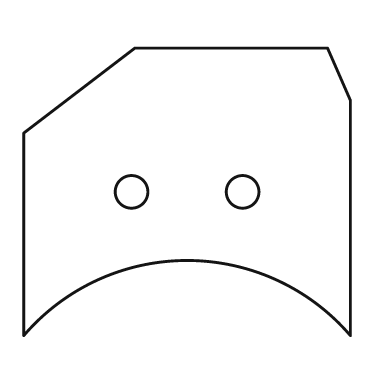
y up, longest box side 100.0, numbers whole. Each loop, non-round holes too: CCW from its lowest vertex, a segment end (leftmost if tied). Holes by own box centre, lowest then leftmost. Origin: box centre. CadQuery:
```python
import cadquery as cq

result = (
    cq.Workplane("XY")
    .moveTo(-50.0, -44.0)
    .threePointArc((0.0, -21.0), (50.0, -44.0))
    .lineTo(50.0, 28.0)
    .lineTo(43.0, 44.0)
    .lineTo(-16.0, 44.0)
    .lineTo(-50.0, 18.0)
    .close()
    .moveTo(-17.0, 0.0)
    .circle(5.0)
    .moveTo(17.0, 0.0)
    .circle(5.0)
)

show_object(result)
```